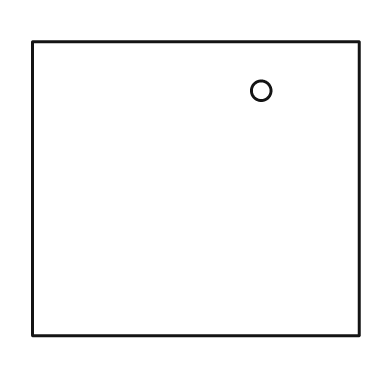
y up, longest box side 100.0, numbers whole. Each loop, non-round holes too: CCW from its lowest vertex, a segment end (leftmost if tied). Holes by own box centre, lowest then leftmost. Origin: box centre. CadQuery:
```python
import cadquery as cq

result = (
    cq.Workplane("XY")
    .moveTo(-50.0, -45.0)
    .lineTo(50.0, -45.0)
    .lineTo(50.0, 45.0)
    .lineTo(-50.0, 45.0)
    .close()
    .moveTo(20.0, 30.0)
    .circle(3.0)
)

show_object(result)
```